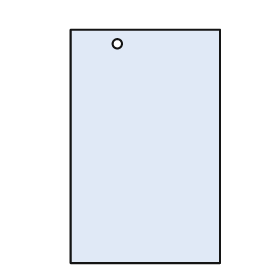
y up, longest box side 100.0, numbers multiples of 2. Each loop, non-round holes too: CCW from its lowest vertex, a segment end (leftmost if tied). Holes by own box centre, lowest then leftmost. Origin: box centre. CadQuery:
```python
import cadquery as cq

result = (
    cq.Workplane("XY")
    .moveTo(-32.0, -50.0)
    .lineTo(32.0, -50.0)
    .lineTo(32.0, 50.0)
    .lineTo(-32.0, 50.0)
    .close()
    .moveTo(-12.0, 44.0)
    .circle(2.0)
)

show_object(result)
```